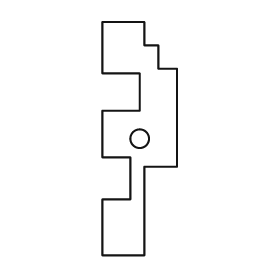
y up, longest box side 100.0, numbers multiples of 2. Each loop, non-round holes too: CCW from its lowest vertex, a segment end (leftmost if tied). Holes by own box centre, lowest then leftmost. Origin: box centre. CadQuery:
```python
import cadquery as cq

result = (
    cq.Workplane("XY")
    .moveTo(-16.0, -50.0)
    .lineTo(2.0, -50.0)
    .lineTo(2.0, -12.0)
    .lineTo(16.0, -12.0)
    .lineTo(16.0, 30.0)
    .lineTo(8.0, 30.0)
    .lineTo(8.0, 40.0)
    .lineTo(2.0, 40.0)
    .lineTo(2.0, 50.0)
    .lineTo(-16.0, 50.0)
    .lineTo(-16.0, 28.0)
    .lineTo(0.0, 28.0)
    .lineTo(0.0, 12.0)
    .lineTo(-16.0, 12.0)
    .lineTo(-16.0, -8.0)
    .lineTo(-4.0, -8.0)
    .lineTo(-4.0, -26.0)
    .lineTo(-16.0, -26.0)
    .close()
    .moveTo(0.0, 0.0)
    .circle(4.0)
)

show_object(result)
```